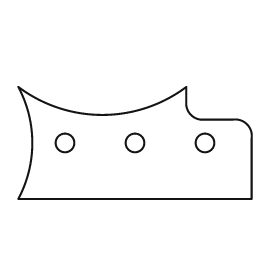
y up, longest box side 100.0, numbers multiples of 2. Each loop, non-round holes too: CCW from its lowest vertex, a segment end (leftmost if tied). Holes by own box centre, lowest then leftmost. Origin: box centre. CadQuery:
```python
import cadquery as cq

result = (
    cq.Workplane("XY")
    .moveTo(-50.0, -24.0)
    .lineTo(50.0, -24.0)
    .lineTo(50.0, 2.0)
    .threePointArc((48.0, 8.0), (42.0, 10.0))
    .lineTo(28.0, 10.0)
    .threePointArc((24.0, 12.0), (22.0, 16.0))
    .lineTo(22.0, 24.0)
    .threePointArc((-14.0, 12.0), (-50.0, 24.0))
    .threePointArc((-44.0, 0.0), (-50.0, -24.0))
    .close()
    .moveTo(-30.0, 0.0)
    .circle(4.0)
    .moveTo(0.0, 0.0)
    .circle(4.0)
    .moveTo(30.0, 0.0)
    .circle(4.0)
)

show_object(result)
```